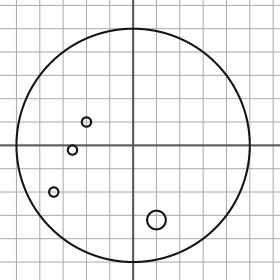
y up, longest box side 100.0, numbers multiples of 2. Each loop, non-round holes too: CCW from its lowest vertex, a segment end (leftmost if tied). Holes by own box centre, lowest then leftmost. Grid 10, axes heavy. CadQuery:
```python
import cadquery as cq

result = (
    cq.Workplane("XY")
    .moveTo(0.0, 0.0)
    .circle(50.0)
    .moveTo(10.0, -32.0)
    .circle(4.0)
    .moveTo(-34.0, -20.0)
    .circle(2.0)
    .moveTo(-26.0, -2.0)
    .circle(2.0)
    .moveTo(-20.0, 10.0)
    .circle(2.0)
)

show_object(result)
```